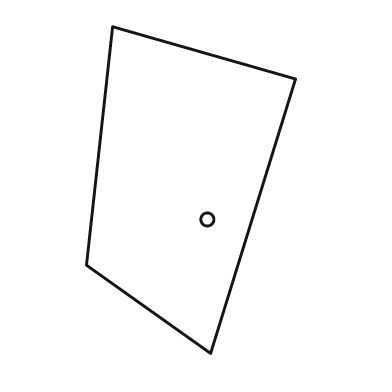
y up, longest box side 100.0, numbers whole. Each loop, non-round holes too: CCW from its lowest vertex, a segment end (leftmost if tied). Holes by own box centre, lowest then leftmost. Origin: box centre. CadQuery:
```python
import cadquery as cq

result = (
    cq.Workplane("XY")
    .moveTo(6.0, -50.0)
    .lineTo(32.0, 34.0)
    .lineTo(-24.0, 50.0)
    .lineTo(-32.0, -23.0)
    .close()
    .moveTo(5.0, -9.0)
    .circle(2.0)
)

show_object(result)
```